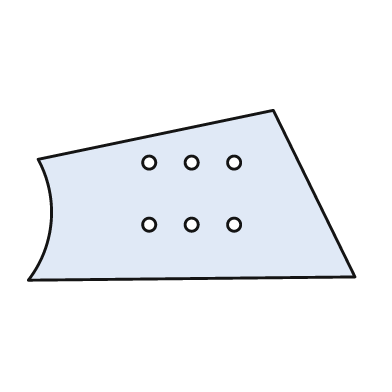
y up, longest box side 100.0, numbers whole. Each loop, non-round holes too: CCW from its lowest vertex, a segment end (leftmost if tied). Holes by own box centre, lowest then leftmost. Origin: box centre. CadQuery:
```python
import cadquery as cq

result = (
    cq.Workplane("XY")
    .moveTo(-50.0, -26.0)
    .lineTo(50.0, -25.0)
    .lineTo(25.0, 26.0)
    .lineTo(-47.0, 11.0)
    .threePointArc((-43.0, -8.0), (-50.0, -26.0))
    .close()
    .moveTo(-13.0, -9.0)
    .circle(2.0)
    .moveTo(0.0, -9.0)
    .circle(2.0)
    .moveTo(13.0, -9.0)
    .circle(2.0)
    .moveTo(-13.0, 10.0)
    .circle(2.0)
    .moveTo(0.0, 10.0)
    .circle(2.0)
    .moveTo(13.0, 10.0)
    .circle(2.0)
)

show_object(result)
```